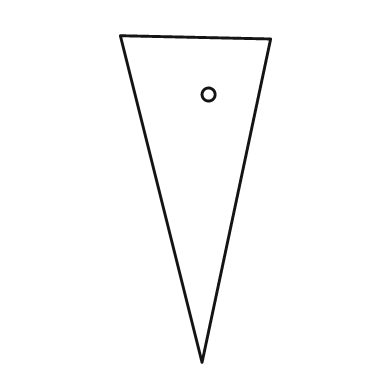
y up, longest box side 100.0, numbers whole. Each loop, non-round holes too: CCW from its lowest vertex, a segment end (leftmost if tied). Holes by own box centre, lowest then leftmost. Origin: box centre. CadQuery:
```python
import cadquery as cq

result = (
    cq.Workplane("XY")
    .moveTo(2.0, -50.0)
    .lineTo(23.0, 49.0)
    .lineTo(-23.0, 50.0)
    .close()
    .moveTo(4.0, 32.0)
    .circle(2.0)
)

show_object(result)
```